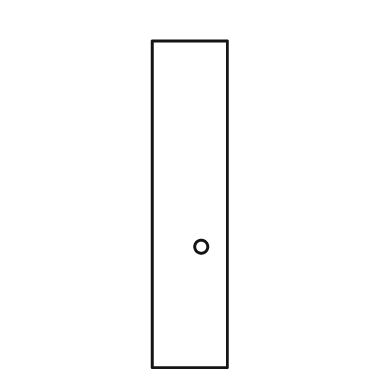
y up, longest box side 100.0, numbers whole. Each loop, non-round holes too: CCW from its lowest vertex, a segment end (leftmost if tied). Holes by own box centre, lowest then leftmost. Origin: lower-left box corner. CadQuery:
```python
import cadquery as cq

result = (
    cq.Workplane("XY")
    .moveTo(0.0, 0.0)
    .lineTo(23.0, 0.0)
    .lineTo(23.0, 100.0)
    .lineTo(0.0, 100.0)
    .close()
    .moveTo(15.0, 37.0)
    .circle(2.0)
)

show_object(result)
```